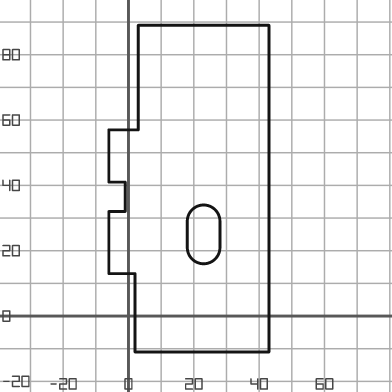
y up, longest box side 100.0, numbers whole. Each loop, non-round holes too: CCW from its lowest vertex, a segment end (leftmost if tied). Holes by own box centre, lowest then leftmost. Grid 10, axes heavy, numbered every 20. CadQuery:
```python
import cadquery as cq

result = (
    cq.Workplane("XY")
    .moveTo(2.0, -11.0)
    .lineTo(43.0, -11.0)
    .lineTo(43.0, 89.0)
    .lineTo(3.0, 89.0)
    .lineTo(3.0, 57.0)
    .lineTo(-6.0, 57.0)
    .lineTo(-6.0, 41.0)
    .lineTo(-1.0, 41.0)
    .lineTo(-1.0, 32.0)
    .lineTo(-6.0, 32.0)
    .lineTo(-6.0, 13.0)
    .lineTo(2.0, 13.0)
    .close()
    .moveTo(18.0, 21.0)
    .threePointArc((23.0, 16.0), (28.0, 21.0))
    .lineTo(28.0, 29.0)
    .threePointArc((23.0, 34.0), (18.0, 29.0))
    .close()
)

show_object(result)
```